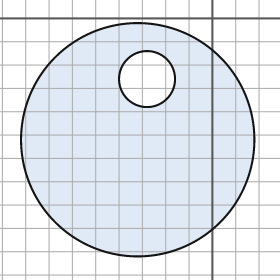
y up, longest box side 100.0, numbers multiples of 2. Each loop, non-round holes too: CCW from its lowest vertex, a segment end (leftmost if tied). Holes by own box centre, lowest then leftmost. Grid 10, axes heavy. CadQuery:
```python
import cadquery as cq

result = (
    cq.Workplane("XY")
    .moveTo(-32.0, -52.0)
    .circle(50.0)
    .moveTo(-28.0, -26.0)
    .circle(12.0)
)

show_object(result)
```